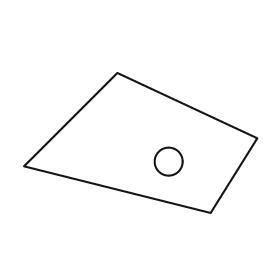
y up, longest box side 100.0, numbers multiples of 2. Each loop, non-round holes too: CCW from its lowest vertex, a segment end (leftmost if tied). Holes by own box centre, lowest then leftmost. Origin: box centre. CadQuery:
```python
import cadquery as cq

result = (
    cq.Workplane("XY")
    .moveTo(30.0, -30.0)
    .lineTo(50.0, 2.0)
    .lineTo(-10.0, 30.0)
    .lineTo(-50.0, -10.0)
    .close()
    .moveTo(12.0, -8.0)
    .circle(6.0)
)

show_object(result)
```